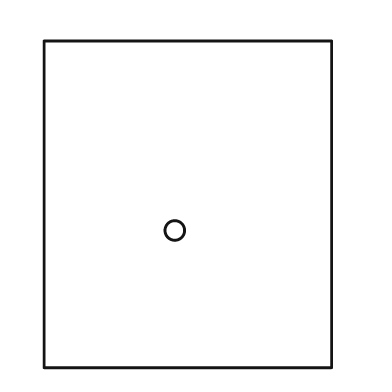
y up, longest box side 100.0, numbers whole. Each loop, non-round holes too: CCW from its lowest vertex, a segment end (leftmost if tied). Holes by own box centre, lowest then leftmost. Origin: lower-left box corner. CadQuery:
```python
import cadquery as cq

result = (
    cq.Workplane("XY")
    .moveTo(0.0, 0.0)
    .lineTo(88.0, 0.0)
    .lineTo(88.0, 100.0)
    .lineTo(0.0, 100.0)
    .close()
    .moveTo(40.0, 42.0)
    .circle(3.0)
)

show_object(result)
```